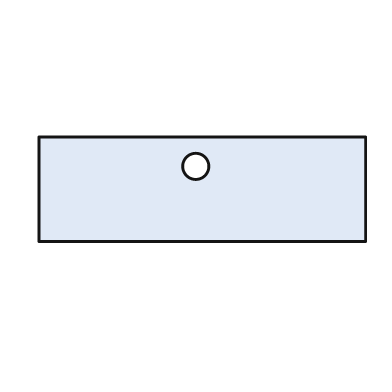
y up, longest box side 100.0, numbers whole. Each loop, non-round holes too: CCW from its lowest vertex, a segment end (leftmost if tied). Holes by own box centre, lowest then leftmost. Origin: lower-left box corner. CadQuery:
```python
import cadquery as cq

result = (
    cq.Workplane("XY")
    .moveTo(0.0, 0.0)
    .lineTo(100.0, 0.0)
    .lineTo(100.0, 32.0)
    .lineTo(0.0, 32.0)
    .close()
    .moveTo(48.0, 23.0)
    .circle(4.0)
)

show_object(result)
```